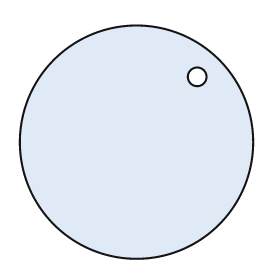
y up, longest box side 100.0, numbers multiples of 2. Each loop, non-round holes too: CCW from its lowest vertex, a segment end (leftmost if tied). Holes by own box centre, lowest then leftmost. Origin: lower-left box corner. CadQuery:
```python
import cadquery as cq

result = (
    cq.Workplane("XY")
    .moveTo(50.0, 50.0)
    .circle(50.0)
    .moveTo(76.0, 78.0)
    .circle(4.0)
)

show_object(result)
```